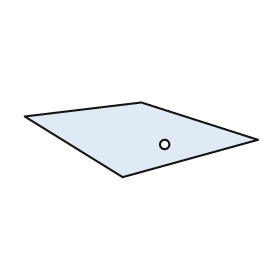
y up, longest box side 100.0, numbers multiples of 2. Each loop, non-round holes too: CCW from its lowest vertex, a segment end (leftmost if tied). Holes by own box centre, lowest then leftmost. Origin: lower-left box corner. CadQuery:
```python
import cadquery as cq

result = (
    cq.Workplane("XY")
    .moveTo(42.0, 0.0)
    .lineTo(100.0, 16.0)
    .lineTo(50.0, 32.0)
    .lineTo(0.0, 26.0)
    .close()
    .moveTo(60.0, 14.0)
    .circle(2.0)
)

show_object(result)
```